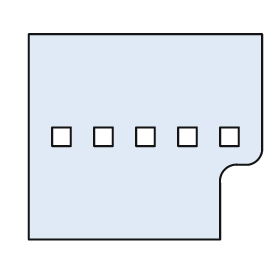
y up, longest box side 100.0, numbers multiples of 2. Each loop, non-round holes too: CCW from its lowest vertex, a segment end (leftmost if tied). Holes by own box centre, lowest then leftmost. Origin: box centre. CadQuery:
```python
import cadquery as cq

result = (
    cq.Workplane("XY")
    .moveTo(-50.0, -44.0)
    .lineTo(32.0, -44.0)
    .lineTo(32.0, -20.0)
    .threePointArc((34.0, -14.0), (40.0, -12.0))
    .lineTo(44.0, -12.0)
    .threePointArc((48.0, -10.0), (50.0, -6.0))
    .lineTo(50.0, 44.0)
    .lineTo(-50.0, 44.0)
    .close()
    .moveTo(-40.0, -4.0)
    .lineTo(-32.0, -4.0)
    .lineTo(-32.0, 4.0)
    .lineTo(-40.0, 4.0)
    .close()
    .moveTo(-22.0, -4.0)
    .lineTo(-14.0, -4.0)
    .lineTo(-14.0, 4.0)
    .lineTo(-22.0, 4.0)
    .close()
    .moveTo(-4.0, -4.0)
    .lineTo(4.0, -4.0)
    .lineTo(4.0, 4.0)
    .lineTo(-4.0, 4.0)
    .close()
    .moveTo(14.0, -4.0)
    .lineTo(22.0, -4.0)
    .lineTo(22.0, 4.0)
    .lineTo(14.0, 4.0)
    .close()
    .moveTo(32.0, -4.0)
    .lineTo(40.0, -4.0)
    .lineTo(40.0, 4.0)
    .lineTo(32.0, 4.0)
    .close()
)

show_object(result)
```